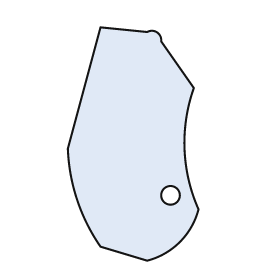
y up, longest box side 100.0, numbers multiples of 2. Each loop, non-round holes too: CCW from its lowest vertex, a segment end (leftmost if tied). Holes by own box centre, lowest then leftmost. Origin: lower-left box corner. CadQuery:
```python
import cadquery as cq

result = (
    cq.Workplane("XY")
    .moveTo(34.0, 0.0)
    .threePointArc((48.0, 8.0), (56.0, 22.0))
    .threePointArc((50.0, 48.0), (54.0, 74.0))
    .lineTo(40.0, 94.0)
    .threePointArc((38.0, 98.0), (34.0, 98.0))
    .lineTo(14.0, 100.0)
    .lineTo(0.0, 48.0)
    .threePointArc((4.0, 26.0), (14.0, 6.0))
    .close()
    .moveTo(44.0, 28.0)
    .circle(4.0)
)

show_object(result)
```